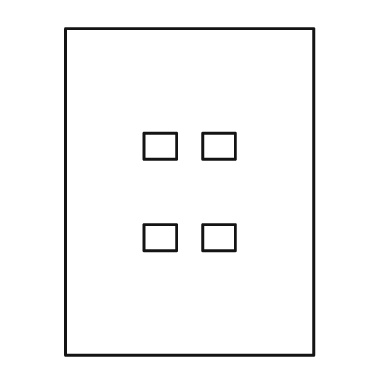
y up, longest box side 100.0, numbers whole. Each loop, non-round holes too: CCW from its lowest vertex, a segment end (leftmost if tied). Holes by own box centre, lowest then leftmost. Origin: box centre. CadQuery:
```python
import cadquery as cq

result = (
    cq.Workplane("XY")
    .moveTo(-38.0, -50.0)
    .lineTo(38.0, -50.0)
    .lineTo(38.0, 50.0)
    .lineTo(-38.0, 50.0)
    .close()
    .moveTo(-14.0, -18.0)
    .lineTo(-4.0, -18.0)
    .lineTo(-4.0, -10.0)
    .lineTo(-14.0, -10.0)
    .close()
    .moveTo(4.0, -18.0)
    .lineTo(14.0, -18.0)
    .lineTo(14.0, -10.0)
    .lineTo(4.0, -10.0)
    .close()
    .moveTo(-14.0, 10.0)
    .lineTo(-4.0, 10.0)
    .lineTo(-4.0, 18.0)
    .lineTo(-14.0, 18.0)
    .close()
    .moveTo(4.0, 10.0)
    .lineTo(14.0, 10.0)
    .lineTo(14.0, 18.0)
    .lineTo(4.0, 18.0)
    .close()
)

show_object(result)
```